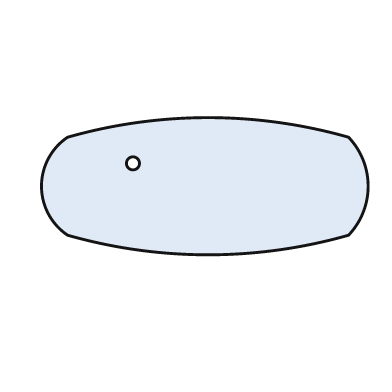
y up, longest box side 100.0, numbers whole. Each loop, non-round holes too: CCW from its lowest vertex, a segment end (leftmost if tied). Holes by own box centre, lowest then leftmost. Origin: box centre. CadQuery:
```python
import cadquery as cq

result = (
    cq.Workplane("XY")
    .moveTo(-42.0, -15.0)
    .threePointArc((1.0, -21.0), (44.0, -15.0))
    .threePointArc((50.0, 0.0), (44.0, 15.0))
    .threePointArc((1.0, 21.0), (-42.0, 15.0))
    .threePointArc((-50.0, 0.0), (-42.0, -15.0))
    .close()
    .moveTo(-22.0, 7.0)
    .circle(2.0)
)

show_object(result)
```